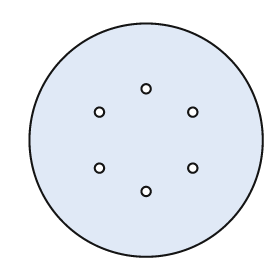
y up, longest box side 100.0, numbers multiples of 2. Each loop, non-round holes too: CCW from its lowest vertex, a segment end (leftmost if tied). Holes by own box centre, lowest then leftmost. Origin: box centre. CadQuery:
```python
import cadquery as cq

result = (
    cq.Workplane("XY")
    .moveTo(0.0, 0.0)
    .circle(50.0)
    .moveTo(0.0, -22.0)
    .circle(2.0)
    .moveTo(-20.0, -12.0)
    .circle(2.0)
    .moveTo(20.0, -12.0)
    .circle(2.0)
    .moveTo(-20.0, 12.0)
    .circle(2.0)
    .moveTo(20.0, 12.0)
    .circle(2.0)
    .moveTo(0.0, 22.0)
    .circle(2.0)
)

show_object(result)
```